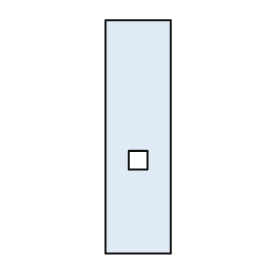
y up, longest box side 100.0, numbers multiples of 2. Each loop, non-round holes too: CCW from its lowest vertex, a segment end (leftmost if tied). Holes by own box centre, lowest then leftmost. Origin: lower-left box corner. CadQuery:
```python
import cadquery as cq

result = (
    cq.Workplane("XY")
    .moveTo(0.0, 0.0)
    .lineTo(28.0, 0.0)
    .lineTo(28.0, 100.0)
    .lineTo(0.0, 100.0)
    .close()
    .moveTo(10.0, 36.0)
    .lineTo(18.0, 36.0)
    .lineTo(18.0, 44.0)
    .lineTo(10.0, 44.0)
    .close()
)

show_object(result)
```